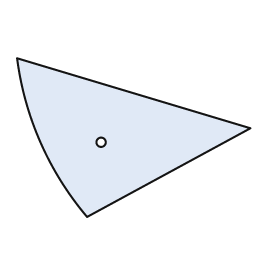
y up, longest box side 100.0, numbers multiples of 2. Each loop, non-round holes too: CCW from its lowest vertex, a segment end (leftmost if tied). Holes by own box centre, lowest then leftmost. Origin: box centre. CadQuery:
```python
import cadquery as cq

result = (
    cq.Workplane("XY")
    .moveTo(-20.0, -34.0)
    .lineTo(50.0, 4.0)
    .lineTo(-50.0, 34.0)
    .threePointArc((-40.0, -2.0), (-20.0, -34.0))
    .close()
    .moveTo(-14.0, -2.0)
    .circle(2.0)
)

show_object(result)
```